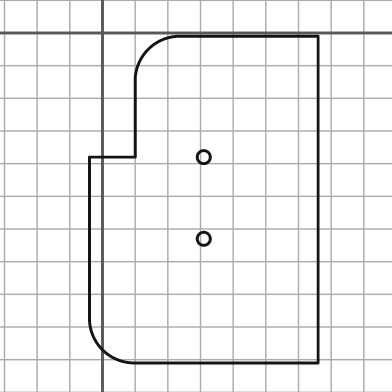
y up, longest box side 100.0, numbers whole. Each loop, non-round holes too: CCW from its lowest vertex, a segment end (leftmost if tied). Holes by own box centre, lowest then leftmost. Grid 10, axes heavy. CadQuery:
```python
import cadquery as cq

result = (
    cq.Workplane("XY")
    .moveTo(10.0, -101.0)
    .lineTo(66.0, -101.0)
    .lineTo(66.0, -1.0)
    .lineTo(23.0, -1.0)
    .threePointArc((14.0, -5.0), (10.0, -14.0))
    .lineTo(10.0, -38.0)
    .lineTo(-4.0, -38.0)
    .lineTo(-4.0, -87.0)
    .threePointArc((0.0, -97.0), (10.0, -101.0))
    .close()
    .moveTo(31.0, -63.0)
    .circle(2.0)
    .moveTo(31.0, -38.0)
    .circle(2.0)
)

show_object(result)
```